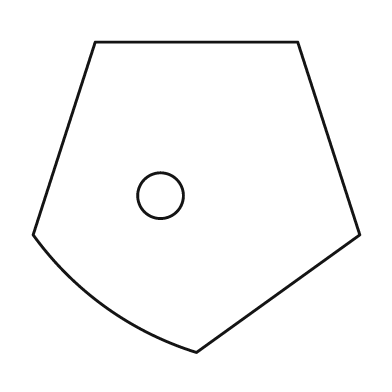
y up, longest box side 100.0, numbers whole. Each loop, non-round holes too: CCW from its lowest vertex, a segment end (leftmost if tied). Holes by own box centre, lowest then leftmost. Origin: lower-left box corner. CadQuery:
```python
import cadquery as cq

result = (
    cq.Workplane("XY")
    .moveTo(50.0, 0.0)
    .lineTo(100.0, 36.0)
    .lineTo(81.0, 95.0)
    .lineTo(19.0, 95.0)
    .lineTo(0.0, 36.0)
    .threePointArc((22.0, 14.0), (50.0, 0.0))
    .close()
    .moveTo(39.0, 48.0)
    .circle(7.0)
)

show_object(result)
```